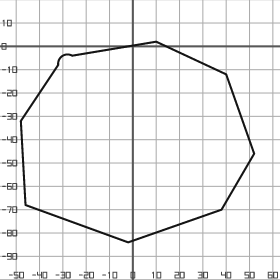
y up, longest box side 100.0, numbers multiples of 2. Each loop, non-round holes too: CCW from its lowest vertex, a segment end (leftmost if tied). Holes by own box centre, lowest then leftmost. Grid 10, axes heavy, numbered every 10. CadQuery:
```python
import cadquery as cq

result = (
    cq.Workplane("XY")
    .moveTo(-2.0, -84.0)
    .lineTo(38.0, -70.0)
    .lineTo(52.0, -46.0)
    .lineTo(40.0, -12.0)
    .lineTo(10.0, 2.0)
    .lineTo(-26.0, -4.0)
    .threePointArc((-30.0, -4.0), (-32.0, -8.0))
    .lineTo(-48.0, -32.0)
    .lineTo(-46.0, -68.0)
    .close()
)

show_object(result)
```